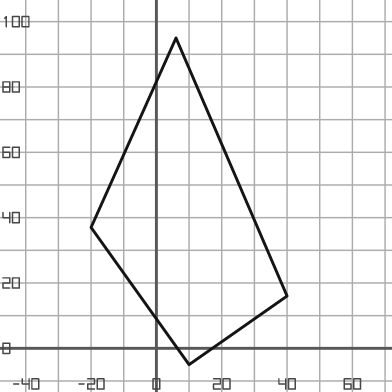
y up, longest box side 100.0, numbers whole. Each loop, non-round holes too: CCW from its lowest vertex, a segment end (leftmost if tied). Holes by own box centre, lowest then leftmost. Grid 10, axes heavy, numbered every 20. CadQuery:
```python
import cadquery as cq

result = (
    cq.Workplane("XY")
    .moveTo(10.0, -5.0)
    .lineTo(40.0, 16.0)
    .lineTo(6.0, 95.0)
    .lineTo(-20.0, 37.0)
    .close()
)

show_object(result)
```